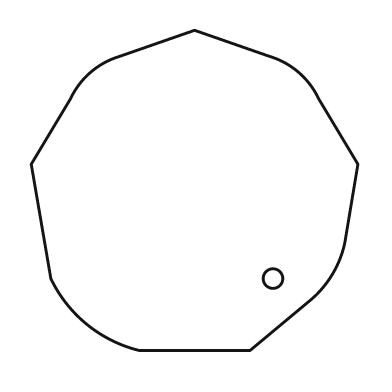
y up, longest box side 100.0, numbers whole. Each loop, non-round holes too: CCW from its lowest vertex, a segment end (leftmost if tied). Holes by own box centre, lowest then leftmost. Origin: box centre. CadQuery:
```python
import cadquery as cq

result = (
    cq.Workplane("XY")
    .moveTo(-17.0, -49.0)
    .lineTo(17.0, -49.0)
    .lineTo(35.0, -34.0)
    .threePointArc((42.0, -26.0), (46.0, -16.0))
    .lineTo(50.0, 8.0)
    .lineTo(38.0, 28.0)
    .threePointArc((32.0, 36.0), (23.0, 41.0))
    .lineTo(0.0, 49.0)
    .lineTo(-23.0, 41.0)
    .threePointArc((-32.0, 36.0), (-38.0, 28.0))
    .lineTo(-50.0, 8.0)
    .lineTo(-44.0, -27.0)
    .threePointArc((-33.0, -41.0), (-17.0, -49.0))
    .close()
    .moveTo(24.0, -27.0)
    .circle(3.0)
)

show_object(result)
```